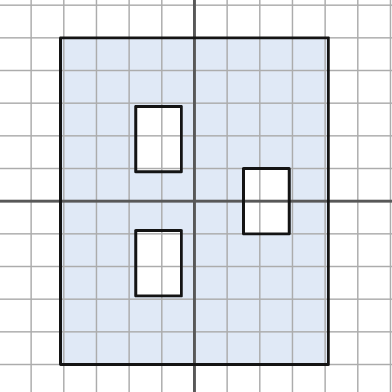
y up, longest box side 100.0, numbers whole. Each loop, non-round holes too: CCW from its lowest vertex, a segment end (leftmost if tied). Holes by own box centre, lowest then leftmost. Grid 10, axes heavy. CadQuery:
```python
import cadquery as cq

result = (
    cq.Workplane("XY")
    .moveTo(-41.0, -50.0)
    .lineTo(41.0, -50.0)
    .lineTo(41.0, 50.0)
    .lineTo(-41.0, 50.0)
    .close()
    .moveTo(-18.0, -29.0)
    .lineTo(-4.0, -29.0)
    .lineTo(-4.0, -9.0)
    .lineTo(-18.0, -9.0)
    .close()
    .moveTo(15.0, -10.0)
    .lineTo(29.0, -10.0)
    .lineTo(29.0, 10.0)
    .lineTo(15.0, 10.0)
    .close()
    .moveTo(-18.0, 9.0)
    .lineTo(-4.0, 9.0)
    .lineTo(-4.0, 29.0)
    .lineTo(-18.0, 29.0)
    .close()
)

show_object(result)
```